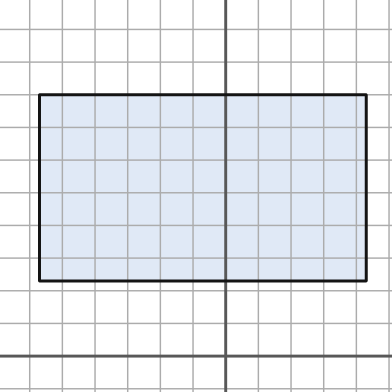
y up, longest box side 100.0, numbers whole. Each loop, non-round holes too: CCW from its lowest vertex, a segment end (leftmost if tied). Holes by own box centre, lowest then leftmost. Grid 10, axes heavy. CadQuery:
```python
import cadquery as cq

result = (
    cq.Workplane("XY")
    .moveTo(-57.0, 23.0)
    .lineTo(43.0, 23.0)
    .lineTo(43.0, 80.0)
    .lineTo(-57.0, 80.0)
    .close()
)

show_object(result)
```